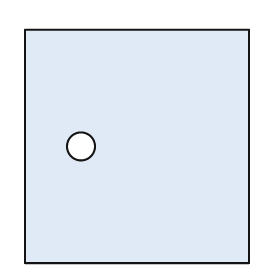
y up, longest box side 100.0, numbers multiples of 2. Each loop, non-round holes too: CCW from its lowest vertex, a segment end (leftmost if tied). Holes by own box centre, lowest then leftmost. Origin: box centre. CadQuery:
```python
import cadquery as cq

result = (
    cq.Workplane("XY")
    .moveTo(-48.0, -50.0)
    .lineTo(48.0, -50.0)
    .lineTo(48.0, 50.0)
    .lineTo(-48.0, 50.0)
    .close()
    .moveTo(-24.0, 0.0)
    .circle(6.0)
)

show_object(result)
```